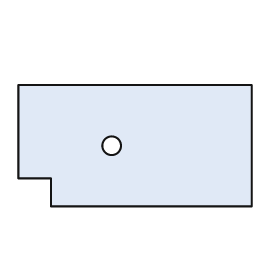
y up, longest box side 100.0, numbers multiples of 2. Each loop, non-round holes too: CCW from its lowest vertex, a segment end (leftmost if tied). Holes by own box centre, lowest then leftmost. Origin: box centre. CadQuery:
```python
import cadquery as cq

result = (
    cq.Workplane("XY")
    .moveTo(-36.0, -26.0)
    .lineTo(50.0, -26.0)
    .lineTo(50.0, 26.0)
    .lineTo(-50.0, 26.0)
    .lineTo(-50.0, -14.0)
    .lineTo(-36.0, -14.0)
    .close()
    .moveTo(-10.0, 0.0)
    .circle(4.0)
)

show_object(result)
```